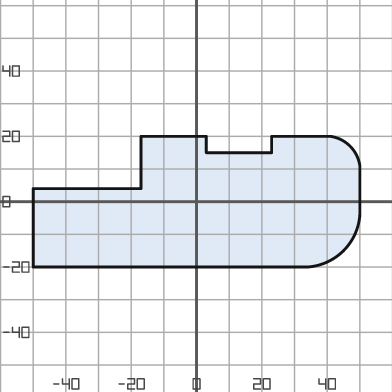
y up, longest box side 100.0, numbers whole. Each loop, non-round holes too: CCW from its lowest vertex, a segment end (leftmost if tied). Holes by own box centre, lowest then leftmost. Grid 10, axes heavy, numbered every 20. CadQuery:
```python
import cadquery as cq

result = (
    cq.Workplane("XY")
    .moveTo(-50.0, -20.0)
    .lineTo(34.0, -20.0)
    .threePointArc((45.0, -15.0), (50.0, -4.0))
    .lineTo(50.0, 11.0)
    .threePointArc((47.0, 17.0), (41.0, 20.0))
    .lineTo(23.0, 20.0)
    .lineTo(23.0, 15.0)
    .lineTo(3.0, 15.0)
    .lineTo(3.0, 20.0)
    .lineTo(-17.0, 20.0)
    .lineTo(-17.0, 4.0)
    .lineTo(-50.0, 4.0)
    .close()
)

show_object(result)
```